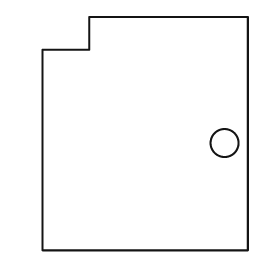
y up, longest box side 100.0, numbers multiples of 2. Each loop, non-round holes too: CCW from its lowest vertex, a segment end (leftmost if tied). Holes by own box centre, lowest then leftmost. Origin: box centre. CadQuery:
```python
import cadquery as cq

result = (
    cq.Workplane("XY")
    .moveTo(-44.0, -50.0)
    .lineTo(44.0, -50.0)
    .lineTo(44.0, 50.0)
    .lineTo(-24.0, 50.0)
    .lineTo(-24.0, 36.0)
    .lineTo(-44.0, 36.0)
    .close()
    .moveTo(34.0, -4.0)
    .circle(6.0)
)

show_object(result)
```